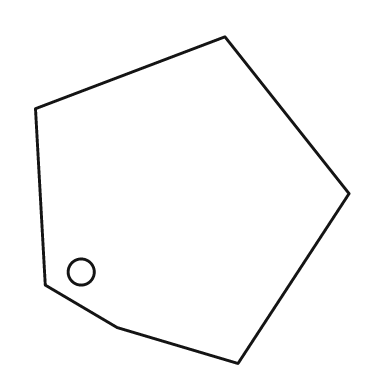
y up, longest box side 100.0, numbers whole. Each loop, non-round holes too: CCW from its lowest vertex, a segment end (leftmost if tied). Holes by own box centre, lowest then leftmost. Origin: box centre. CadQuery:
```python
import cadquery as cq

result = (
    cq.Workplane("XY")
    .moveTo(14.0, -50.0)
    .lineTo(48.0, 2.0)
    .lineTo(10.0, 50.0)
    .lineTo(-48.0, 28.0)
    .lineTo(-45.0, -26.0)
    .lineTo(-23.0, -39.0)
    .close()
    .moveTo(-34.0, -22.0)
    .circle(4.0)
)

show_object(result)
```